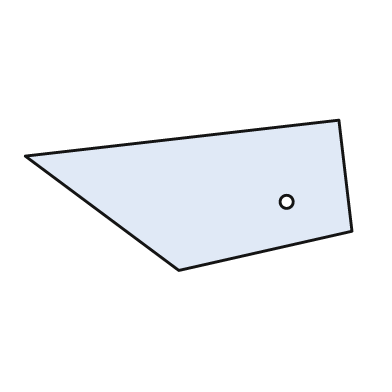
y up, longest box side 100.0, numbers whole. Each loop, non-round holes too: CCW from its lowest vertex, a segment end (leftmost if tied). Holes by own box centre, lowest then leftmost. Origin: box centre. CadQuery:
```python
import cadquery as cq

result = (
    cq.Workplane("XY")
    .moveTo(-3.0, -23.0)
    .lineTo(50.0, -11.0)
    .lineTo(46.0, 23.0)
    .lineTo(-50.0, 12.0)
    .close()
    .moveTo(30.0, -2.0)
    .circle(2.0)
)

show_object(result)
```